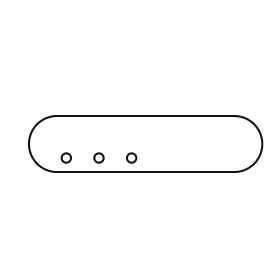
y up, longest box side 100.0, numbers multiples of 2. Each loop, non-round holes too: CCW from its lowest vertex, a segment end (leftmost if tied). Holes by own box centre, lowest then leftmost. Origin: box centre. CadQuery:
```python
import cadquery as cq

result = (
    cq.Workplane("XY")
    .moveTo(-38.0, -12.0)
    .lineTo(38.0, -12.0)
    .threePointArc((50.0, 0.0), (38.0, 12.0))
    .lineTo(-38.0, 12.0)
    .threePointArc((-50.0, 0.0), (-38.0, -12.0))
    .close()
    .moveTo(-34.0, -6.0)
    .circle(2.0)
    .moveTo(-20.0, -6.0)
    .circle(2.0)
    .moveTo(-6.0, -6.0)
    .circle(2.0)
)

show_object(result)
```